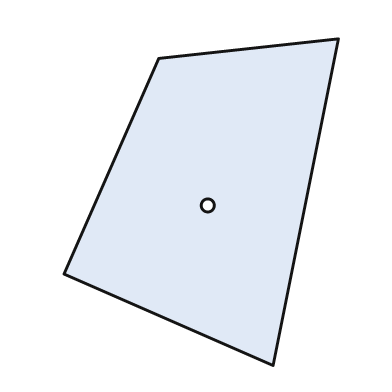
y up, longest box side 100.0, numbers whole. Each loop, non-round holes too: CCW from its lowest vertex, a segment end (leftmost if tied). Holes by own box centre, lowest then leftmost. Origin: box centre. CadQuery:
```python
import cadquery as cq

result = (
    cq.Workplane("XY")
    .moveTo(22.0, -50.0)
    .lineTo(42.0, 50.0)
    .lineTo(-13.0, 44.0)
    .lineTo(-42.0, -22.0)
    .close()
    .moveTo(2.0, -1.0)
    .circle(2.0)
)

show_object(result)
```